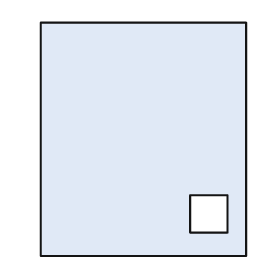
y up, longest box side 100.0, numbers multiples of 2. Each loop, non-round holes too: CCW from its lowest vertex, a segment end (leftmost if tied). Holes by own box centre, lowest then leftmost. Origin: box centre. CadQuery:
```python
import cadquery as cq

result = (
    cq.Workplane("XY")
    .moveTo(-44.0, -50.0)
    .lineTo(44.0, -50.0)
    .lineTo(44.0, 50.0)
    .lineTo(-44.0, 50.0)
    .close()
    .moveTo(20.0, -40.0)
    .lineTo(36.0, -40.0)
    .lineTo(36.0, -24.0)
    .lineTo(20.0, -24.0)
    .close()
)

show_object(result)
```